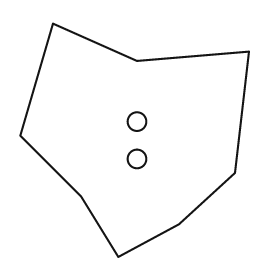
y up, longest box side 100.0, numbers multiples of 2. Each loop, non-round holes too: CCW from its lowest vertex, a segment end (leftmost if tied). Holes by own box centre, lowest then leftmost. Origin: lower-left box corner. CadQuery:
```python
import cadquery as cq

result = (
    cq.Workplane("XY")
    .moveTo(42.0, 0.0)
    .lineTo(68.0, 14.0)
    .lineTo(92.0, 36.0)
    .lineTo(98.0, 88.0)
    .lineTo(50.0, 84.0)
    .lineTo(14.0, 100.0)
    .lineTo(0.0, 52.0)
    .lineTo(26.0, 26.0)
    .close()
    .moveTo(50.0, 42.0)
    .circle(4.0)
    .moveTo(50.0, 58.0)
    .circle(4.0)
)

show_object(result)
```